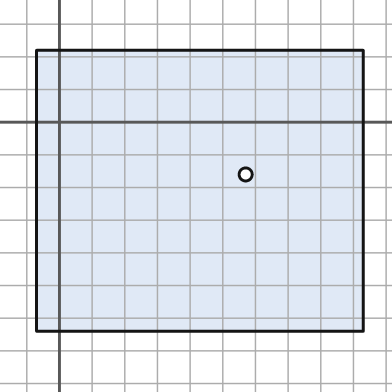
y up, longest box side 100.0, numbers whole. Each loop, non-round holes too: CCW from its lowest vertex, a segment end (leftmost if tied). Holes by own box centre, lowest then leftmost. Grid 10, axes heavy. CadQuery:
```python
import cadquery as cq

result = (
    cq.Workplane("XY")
    .moveTo(-7.0, -64.0)
    .lineTo(93.0, -64.0)
    .lineTo(93.0, 22.0)
    .lineTo(-7.0, 22.0)
    .close()
    .moveTo(57.0, -16.0)
    .circle(2.0)
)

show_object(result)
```